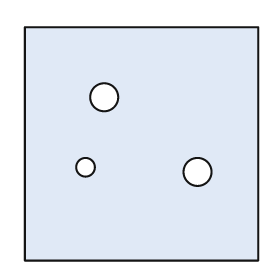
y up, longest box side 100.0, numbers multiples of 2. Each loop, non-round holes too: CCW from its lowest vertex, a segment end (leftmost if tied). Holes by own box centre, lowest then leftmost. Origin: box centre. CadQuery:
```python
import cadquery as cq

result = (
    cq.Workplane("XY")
    .moveTo(-50.0, -50.0)
    .lineTo(50.0, -50.0)
    .lineTo(50.0, 50.0)
    .lineTo(-50.0, 50.0)
    .close()
    .moveTo(24.0, -12.0)
    .circle(6.0)
    .moveTo(-24.0, -10.0)
    .circle(4.0)
    .moveTo(-16.0, 20.0)
    .circle(6.0)
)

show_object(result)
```